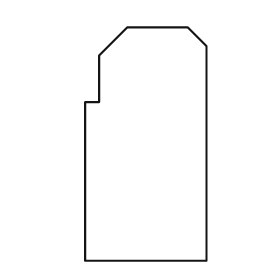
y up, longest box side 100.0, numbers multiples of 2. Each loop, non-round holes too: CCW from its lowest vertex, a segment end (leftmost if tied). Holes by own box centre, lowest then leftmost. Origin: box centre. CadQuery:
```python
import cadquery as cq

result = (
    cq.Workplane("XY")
    .moveTo(-26.0, -50.0)
    .lineTo(26.0, -50.0)
    .lineTo(26.0, 42.0)
    .lineTo(18.0, 50.0)
    .lineTo(-8.0, 50.0)
    .lineTo(-20.0, 38.0)
    .lineTo(-20.0, 18.0)
    .lineTo(-26.0, 18.0)
    .close()
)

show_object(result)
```